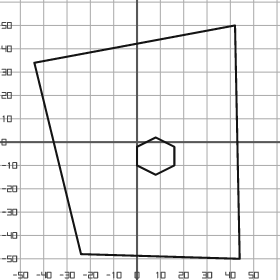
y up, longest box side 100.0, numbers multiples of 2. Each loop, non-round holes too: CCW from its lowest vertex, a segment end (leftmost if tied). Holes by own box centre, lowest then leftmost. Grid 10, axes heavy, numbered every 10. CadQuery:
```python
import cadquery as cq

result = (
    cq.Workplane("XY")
    .moveTo(44.0, -50.0)
    .lineTo(42.0, 50.0)
    .lineTo(-44.0, 34.0)
    .lineTo(-24.0, -48.0)
    .close()
    .moveTo(8.0, -14.0)
    .lineTo(16.0, -10.0)
    .lineTo(16.0, -2.0)
    .lineTo(8.0, 2.0)
    .lineTo(0.0, -2.0)
    .lineTo(0.0, -10.0)
    .close()
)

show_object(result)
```